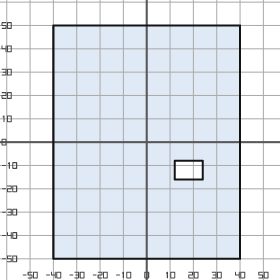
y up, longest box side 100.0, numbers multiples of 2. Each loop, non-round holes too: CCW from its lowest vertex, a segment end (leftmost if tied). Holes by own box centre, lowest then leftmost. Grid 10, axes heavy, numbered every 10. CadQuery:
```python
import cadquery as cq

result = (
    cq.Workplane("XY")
    .moveTo(-40.0, -50.0)
    .lineTo(40.0, -50.0)
    .lineTo(40.0, 50.0)
    .lineTo(-40.0, 50.0)
    .close()
    .moveTo(12.0, -16.0)
    .lineTo(24.0, -16.0)
    .lineTo(24.0, -8.0)
    .lineTo(12.0, -8.0)
    .close()
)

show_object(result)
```